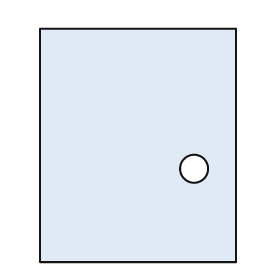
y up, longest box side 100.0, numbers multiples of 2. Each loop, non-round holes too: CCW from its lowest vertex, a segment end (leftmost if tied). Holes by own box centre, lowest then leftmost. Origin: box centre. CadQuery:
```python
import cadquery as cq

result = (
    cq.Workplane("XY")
    .moveTo(-42.0, -50.0)
    .lineTo(42.0, -50.0)
    .lineTo(42.0, 50.0)
    .lineTo(-42.0, 50.0)
    .close()
    .moveTo(24.0, -10.0)
    .circle(6.0)
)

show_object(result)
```